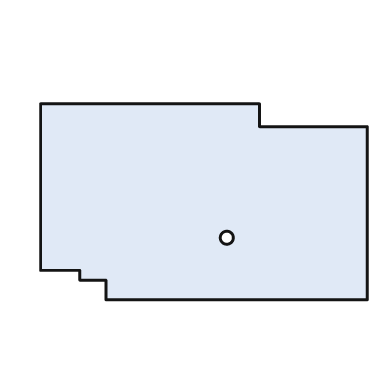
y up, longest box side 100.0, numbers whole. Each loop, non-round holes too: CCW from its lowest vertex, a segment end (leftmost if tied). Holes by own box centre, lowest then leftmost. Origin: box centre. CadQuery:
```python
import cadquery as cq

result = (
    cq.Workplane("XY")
    .moveTo(-30.0, -30.0)
    .lineTo(50.0, -30.0)
    .lineTo(50.0, 23.0)
    .lineTo(17.0, 23.0)
    .lineTo(17.0, 30.0)
    .lineTo(-50.0, 30.0)
    .lineTo(-50.0, -21.0)
    .lineTo(-38.0, -21.0)
    .lineTo(-38.0, -24.0)
    .lineTo(-30.0, -24.0)
    .close()
    .moveTo(7.0, -11.0)
    .circle(2.0)
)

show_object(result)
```